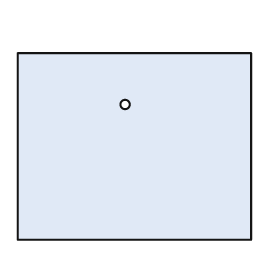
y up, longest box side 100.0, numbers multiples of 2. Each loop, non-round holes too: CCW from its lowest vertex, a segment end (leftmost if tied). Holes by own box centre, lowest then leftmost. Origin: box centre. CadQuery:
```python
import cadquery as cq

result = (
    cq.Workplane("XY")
    .moveTo(-50.0, -40.0)
    .lineTo(50.0, -40.0)
    .lineTo(50.0, 40.0)
    .lineTo(-50.0, 40.0)
    .close()
    .moveTo(-4.0, 18.0)
    .circle(2.0)
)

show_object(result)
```